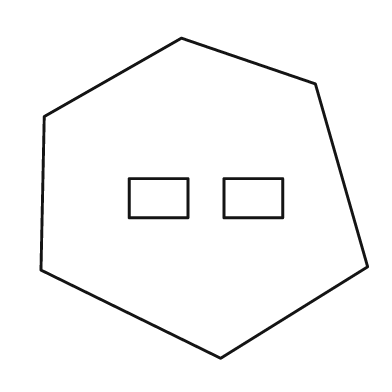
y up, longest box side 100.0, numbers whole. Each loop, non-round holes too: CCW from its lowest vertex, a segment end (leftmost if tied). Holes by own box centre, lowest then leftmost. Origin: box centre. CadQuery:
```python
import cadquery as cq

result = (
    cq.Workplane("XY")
    .moveTo(5.0, -49.0)
    .lineTo(50.0, -21.0)
    .lineTo(34.0, 35.0)
    .lineTo(-7.0, 49.0)
    .lineTo(-49.0, 25.0)
    .lineTo(-50.0, -22.0)
    .close()
    .moveTo(-23.0, -6.0)
    .lineTo(-5.0, -6.0)
    .lineTo(-5.0, 6.0)
    .lineTo(-23.0, 6.0)
    .close()
    .moveTo(6.0, -6.0)
    .lineTo(24.0, -6.0)
    .lineTo(24.0, 6.0)
    .lineTo(6.0, 6.0)
    .close()
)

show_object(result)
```